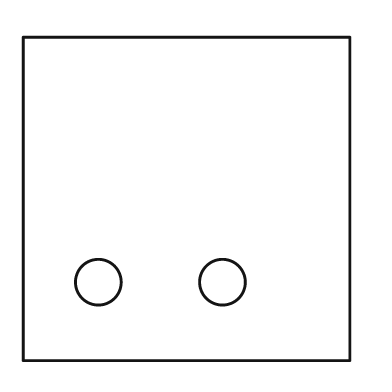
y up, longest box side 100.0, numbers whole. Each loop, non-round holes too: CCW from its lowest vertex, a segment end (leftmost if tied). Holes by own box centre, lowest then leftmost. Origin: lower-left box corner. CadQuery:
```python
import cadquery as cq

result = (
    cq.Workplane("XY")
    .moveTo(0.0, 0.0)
    .lineTo(100.0, 0.0)
    .lineTo(100.0, 99.0)
    .lineTo(0.0, 99.0)
    .close()
    .moveTo(23.0, 24.0)
    .circle(7.0)
    .moveTo(61.0, 24.0)
    .circle(7.0)
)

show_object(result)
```